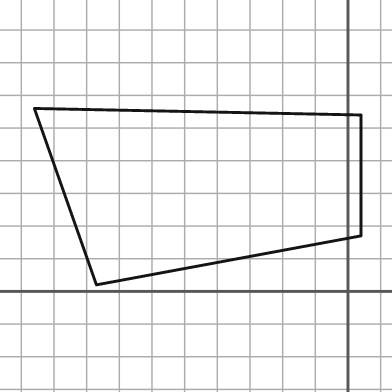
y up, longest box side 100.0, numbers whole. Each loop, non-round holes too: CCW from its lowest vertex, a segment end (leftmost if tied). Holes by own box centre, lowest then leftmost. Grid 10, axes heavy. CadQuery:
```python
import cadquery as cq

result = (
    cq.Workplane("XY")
    .moveTo(-77.0, 2.0)
    .lineTo(4.0, 17.0)
    .lineTo(4.0, 54.0)
    .lineTo(-96.0, 56.0)
    .close()
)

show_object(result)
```